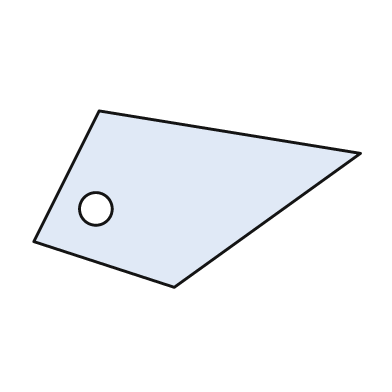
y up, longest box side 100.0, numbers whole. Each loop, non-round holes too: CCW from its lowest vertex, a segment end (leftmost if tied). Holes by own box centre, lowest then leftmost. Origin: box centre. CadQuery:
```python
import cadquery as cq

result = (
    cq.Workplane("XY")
    .moveTo(-7.0, -27.0)
    .lineTo(50.0, 14.0)
    .lineTo(-30.0, 27.0)
    .lineTo(-50.0, -13.0)
    .close()
    .moveTo(-31.0, -3.0)
    .circle(5.0)
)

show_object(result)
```